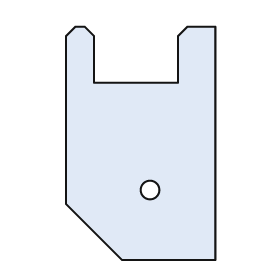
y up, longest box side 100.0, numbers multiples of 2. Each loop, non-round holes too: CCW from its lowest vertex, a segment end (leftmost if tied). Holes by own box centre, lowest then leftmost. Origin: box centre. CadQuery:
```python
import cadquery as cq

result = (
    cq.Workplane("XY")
    .moveTo(-8.0, -50.0)
    .lineTo(32.0, -50.0)
    .lineTo(32.0, 50.0)
    .lineTo(20.0, 50.0)
    .lineTo(16.0, 46.0)
    .lineTo(16.0, 26.0)
    .lineTo(-20.0, 26.0)
    .lineTo(-20.0, 46.0)
    .lineTo(-24.0, 50.0)
    .lineTo(-28.0, 50.0)
    .lineTo(-32.0, 46.0)
    .lineTo(-32.0, -26.0)
    .close()
    .moveTo(4.0, -20.0)
    .circle(4.0)
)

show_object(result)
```